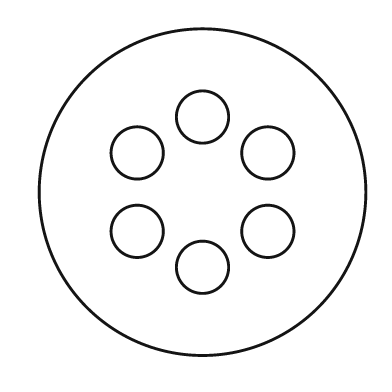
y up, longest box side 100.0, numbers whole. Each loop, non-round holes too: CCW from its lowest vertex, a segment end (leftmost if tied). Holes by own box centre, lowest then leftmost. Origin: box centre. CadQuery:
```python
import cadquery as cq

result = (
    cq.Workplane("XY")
    .moveTo(0.0, 0.0)
    .circle(50.0)
    .moveTo(0.0, -23.0)
    .circle(8.0)
    .moveTo(-20.0, -12.0)
    .circle(8.0)
    .moveTo(20.0, -12.0)
    .circle(8.0)
    .moveTo(-20.0, 12.0)
    .circle(8.0)
    .moveTo(20.0, 12.0)
    .circle(8.0)
    .moveTo(0.0, 23.0)
    .circle(8.0)
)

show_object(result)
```